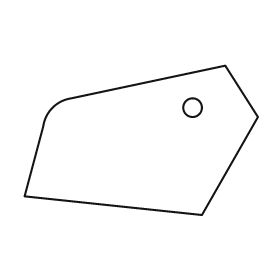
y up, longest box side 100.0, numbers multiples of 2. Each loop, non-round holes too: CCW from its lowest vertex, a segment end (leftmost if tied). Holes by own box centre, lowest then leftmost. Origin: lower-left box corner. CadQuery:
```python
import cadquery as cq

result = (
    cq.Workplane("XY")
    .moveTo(76.0, 0.0)
    .lineTo(100.0, 42.0)
    .lineTo(86.0, 64.0)
    .lineTo(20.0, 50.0)
    .threePointArc((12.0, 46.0), (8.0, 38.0))
    .lineTo(0.0, 8.0)
    .close()
    .moveTo(72.0, 46.0)
    .circle(4.0)
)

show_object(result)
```